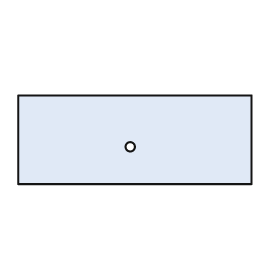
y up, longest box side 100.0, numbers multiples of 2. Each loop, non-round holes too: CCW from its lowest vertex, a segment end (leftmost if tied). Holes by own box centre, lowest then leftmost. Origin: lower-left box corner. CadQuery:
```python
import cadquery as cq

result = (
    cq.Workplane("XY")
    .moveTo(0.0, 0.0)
    .lineTo(100.0, 0.0)
    .lineTo(100.0, 38.0)
    .lineTo(0.0, 38.0)
    .close()
    .moveTo(48.0, 16.0)
    .circle(2.0)
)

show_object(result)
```